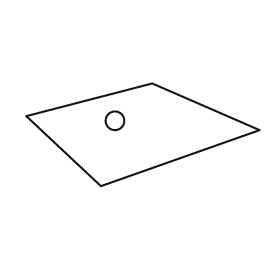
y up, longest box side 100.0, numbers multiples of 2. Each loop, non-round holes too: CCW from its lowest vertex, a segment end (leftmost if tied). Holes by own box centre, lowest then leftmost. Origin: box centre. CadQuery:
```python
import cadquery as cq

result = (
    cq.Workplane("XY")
    .moveTo(-18.0, -22.0)
    .lineTo(50.0, 2.0)
    .lineTo(4.0, 22.0)
    .lineTo(-50.0, 8.0)
    .close()
    .moveTo(-12.0, 6.0)
    .circle(4.0)
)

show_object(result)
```